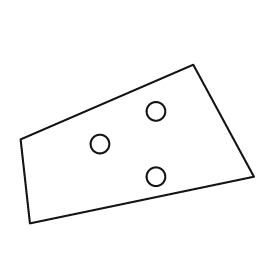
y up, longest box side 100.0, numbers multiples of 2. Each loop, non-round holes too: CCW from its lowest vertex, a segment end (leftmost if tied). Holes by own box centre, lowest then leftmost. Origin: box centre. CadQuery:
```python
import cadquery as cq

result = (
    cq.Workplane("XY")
    .moveTo(-46.0, -34.0)
    .lineTo(50.0, -14.0)
    .lineTo(24.0, 34.0)
    .lineTo(-50.0, 2.0)
    .close()
    .moveTo(8.0, -14.0)
    .circle(4.0)
    .moveTo(-16.0, 0.0)
    .circle(4.0)
    .moveTo(8.0, 14.0)
    .circle(4.0)
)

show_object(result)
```